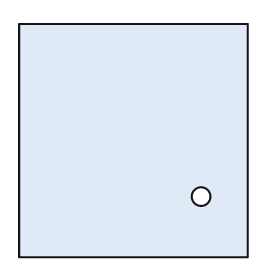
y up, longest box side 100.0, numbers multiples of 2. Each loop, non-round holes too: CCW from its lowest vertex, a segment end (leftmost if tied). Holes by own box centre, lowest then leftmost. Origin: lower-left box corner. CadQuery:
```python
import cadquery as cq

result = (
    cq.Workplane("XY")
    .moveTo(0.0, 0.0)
    .lineTo(98.0, 0.0)
    .lineTo(98.0, 100.0)
    .lineTo(0.0, 100.0)
    .close()
    .moveTo(78.0, 26.0)
    .circle(4.0)
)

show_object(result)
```